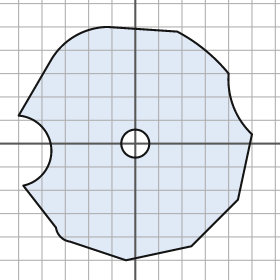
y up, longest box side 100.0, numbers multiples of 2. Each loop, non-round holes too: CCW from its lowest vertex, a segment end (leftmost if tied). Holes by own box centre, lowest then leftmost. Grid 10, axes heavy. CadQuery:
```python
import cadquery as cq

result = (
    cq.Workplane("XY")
    .moveTo(-4.0, -50.0)
    .lineTo(24.0, -44.0)
    .lineTo(44.0, -24.0)
    .lineTo(50.0, 4.0)
    .threePointArc((42.0, 16.0), (40.0, 30.0))
    .threePointArc((30.0, 40.0), (18.0, 48.0))
    .lineTo(-12.0, 50.0)
    .threePointArc((-26.0, 46.0), (-36.0, 36.0))
    .lineTo(-50.0, 12.0)
    .threePointArc((-36.0, -2.0), (-48.0, -18.0))
    .lineTo(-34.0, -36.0)
    .threePointArc((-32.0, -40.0), (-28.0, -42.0))
    .close()
    .moveTo(0.0, 0.0)
    .circle(6.0)
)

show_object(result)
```